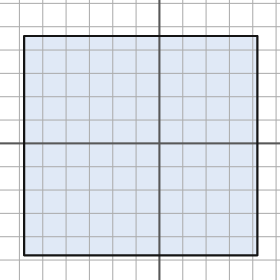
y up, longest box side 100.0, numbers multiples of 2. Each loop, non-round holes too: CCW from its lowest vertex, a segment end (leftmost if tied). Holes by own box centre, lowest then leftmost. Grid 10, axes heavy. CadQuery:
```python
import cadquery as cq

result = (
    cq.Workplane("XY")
    .moveTo(-58.0, -48.0)
    .lineTo(42.0, -48.0)
    .lineTo(42.0, 46.0)
    .lineTo(-58.0, 46.0)
    .close()
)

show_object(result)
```